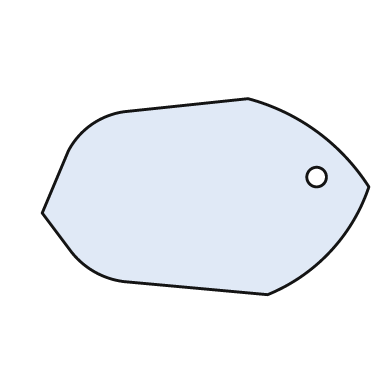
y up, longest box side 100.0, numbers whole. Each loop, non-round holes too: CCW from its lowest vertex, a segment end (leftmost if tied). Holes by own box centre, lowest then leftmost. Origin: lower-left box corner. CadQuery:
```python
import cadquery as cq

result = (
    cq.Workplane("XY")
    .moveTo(69.0, 0.0)
    .threePointArc((88.0, 13.0), (100.0, 33.0))
    .threePointArc((84.0, 50.0), (63.0, 60.0))
    .lineTo(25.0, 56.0)
    .threePointArc((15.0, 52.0), (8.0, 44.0))
    .lineTo(0.0, 25.0)
    .lineTo(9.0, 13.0)
    .threePointArc((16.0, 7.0), (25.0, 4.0))
    .close()
    .moveTo(84.0, 36.0)
    .circle(3.0)
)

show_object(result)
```